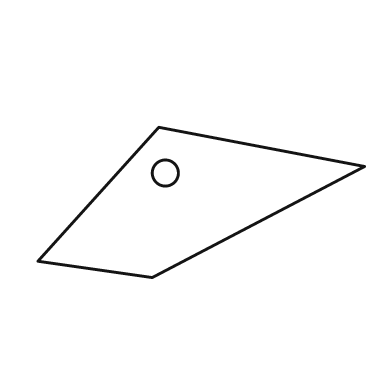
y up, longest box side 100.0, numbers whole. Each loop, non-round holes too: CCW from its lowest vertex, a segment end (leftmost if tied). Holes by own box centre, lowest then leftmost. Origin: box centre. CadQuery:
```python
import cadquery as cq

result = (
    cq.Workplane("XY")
    .moveTo(-15.0, -23.0)
    .lineTo(50.0, 11.0)
    .lineTo(-13.0, 23.0)
    .lineTo(-50.0, -18.0)
    .close()
    .moveTo(-11.0, 9.0)
    .circle(4.0)
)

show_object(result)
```